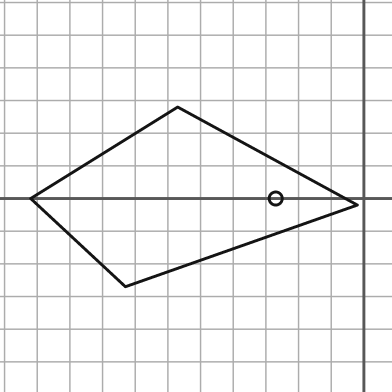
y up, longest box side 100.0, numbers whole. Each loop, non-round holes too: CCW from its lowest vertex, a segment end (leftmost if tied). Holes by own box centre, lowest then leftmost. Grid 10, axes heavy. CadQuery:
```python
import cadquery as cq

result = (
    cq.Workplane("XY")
    .moveTo(-73.0, -27.0)
    .lineTo(-2.0, -2.0)
    .lineTo(-57.0, 28.0)
    .lineTo(-102.0, 0.0)
    .close()
    .moveTo(-27.0, 0.0)
    .circle(2.0)
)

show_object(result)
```